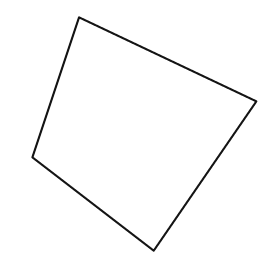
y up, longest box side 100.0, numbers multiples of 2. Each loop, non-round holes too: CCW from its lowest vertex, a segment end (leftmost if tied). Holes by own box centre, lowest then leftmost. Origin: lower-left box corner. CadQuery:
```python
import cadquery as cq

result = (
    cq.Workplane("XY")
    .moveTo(52.0, 0.0)
    .lineTo(96.0, 64.0)
    .lineTo(20.0, 100.0)
    .lineTo(0.0, 40.0)
    .close()
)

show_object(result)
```